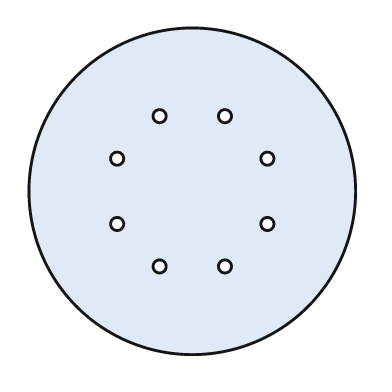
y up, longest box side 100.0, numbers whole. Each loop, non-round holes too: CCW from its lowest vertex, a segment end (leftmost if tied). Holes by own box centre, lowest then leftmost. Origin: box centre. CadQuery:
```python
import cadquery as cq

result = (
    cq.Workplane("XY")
    .moveTo(0.0, 0.0)
    .circle(50.0)
    .moveTo(-10.0, -23.0)
    .circle(2.0)
    .moveTo(10.0, -23.0)
    .circle(2.0)
    .moveTo(-23.0, -10.0)
    .circle(2.0)
    .moveTo(23.0, -10.0)
    .circle(2.0)
    .moveTo(-23.0, 10.0)
    .circle(2.0)
    .moveTo(23.0, 10.0)
    .circle(2.0)
    .moveTo(-10.0, 23.0)
    .circle(2.0)
    .moveTo(10.0, 23.0)
    .circle(2.0)
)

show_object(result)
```